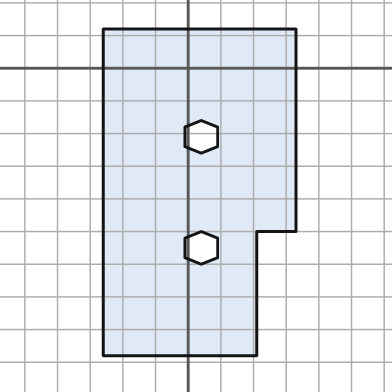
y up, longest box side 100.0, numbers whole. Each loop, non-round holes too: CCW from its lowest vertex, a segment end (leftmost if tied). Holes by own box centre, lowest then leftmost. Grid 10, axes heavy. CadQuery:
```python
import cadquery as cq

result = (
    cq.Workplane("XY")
    .moveTo(-26.0, -88.0)
    .lineTo(21.0, -88.0)
    .lineTo(21.0, -50.0)
    .lineTo(33.0, -50.0)
    .lineTo(33.0, 12.0)
    .lineTo(-26.0, 12.0)
    .close()
    .moveTo(4.0, -60.0)
    .lineTo(9.0, -58.0)
    .lineTo(9.0, -52.0)
    .lineTo(4.0, -50.0)
    .lineTo(-1.0, -52.0)
    .lineTo(-1.0, -58.0)
    .close()
    .moveTo(4.0, -26.0)
    .lineTo(9.0, -24.0)
    .lineTo(9.0, -18.0)
    .lineTo(4.0, -16.0)
    .lineTo(-1.0, -18.0)
    .lineTo(-1.0, -24.0)
    .close()
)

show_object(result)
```